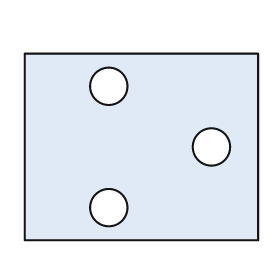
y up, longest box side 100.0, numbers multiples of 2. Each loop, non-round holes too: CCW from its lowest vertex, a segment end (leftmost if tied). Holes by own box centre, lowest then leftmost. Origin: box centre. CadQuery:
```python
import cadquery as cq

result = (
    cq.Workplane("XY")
    .moveTo(-50.0, -40.0)
    .lineTo(50.0, -40.0)
    .lineTo(50.0, 40.0)
    .lineTo(-50.0, 40.0)
    .close()
    .moveTo(-14.0, -26.0)
    .circle(8.0)
    .moveTo(30.0, 0.0)
    .circle(8.0)
    .moveTo(-14.0, 26.0)
    .circle(8.0)
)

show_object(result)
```